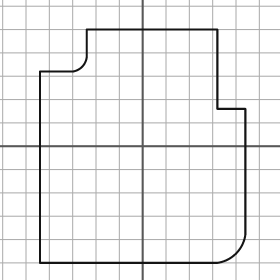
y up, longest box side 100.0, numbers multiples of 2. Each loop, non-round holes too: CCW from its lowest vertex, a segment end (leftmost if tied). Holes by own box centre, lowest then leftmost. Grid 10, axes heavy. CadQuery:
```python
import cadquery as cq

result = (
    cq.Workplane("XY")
    .moveTo(-44.0, -50.0)
    .lineTo(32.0, -50.0)
    .threePointArc((40.0, -46.0), (44.0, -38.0))
    .lineTo(44.0, 16.0)
    .lineTo(32.0, 16.0)
    .lineTo(32.0, 50.0)
    .lineTo(-24.0, 50.0)
    .lineTo(-24.0, 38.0)
    .threePointArc((-26.0, 34.0), (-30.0, 32.0))
    .lineTo(-44.0, 32.0)
    .close()
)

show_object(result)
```